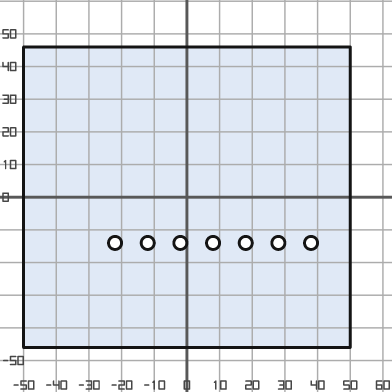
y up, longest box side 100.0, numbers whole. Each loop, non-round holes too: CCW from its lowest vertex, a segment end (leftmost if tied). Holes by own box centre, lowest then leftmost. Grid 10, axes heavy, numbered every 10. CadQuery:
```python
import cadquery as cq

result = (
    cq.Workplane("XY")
    .moveTo(-50.0, -46.0)
    .lineTo(50.0, -46.0)
    .lineTo(50.0, 46.0)
    .lineTo(-50.0, 46.0)
    .close()
    .moveTo(-22.0, -14.0)
    .circle(2.0)
    .moveTo(-12.0, -14.0)
    .circle(2.0)
    .moveTo(-2.0, -14.0)
    .circle(2.0)
    .moveTo(8.0, -14.0)
    .circle(2.0)
    .moveTo(18.0, -14.0)
    .circle(2.0)
    .moveTo(28.0, -14.0)
    .circle(2.0)
    .moveTo(38.0, -14.0)
    .circle(2.0)
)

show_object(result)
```